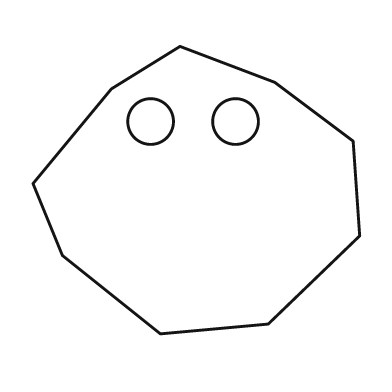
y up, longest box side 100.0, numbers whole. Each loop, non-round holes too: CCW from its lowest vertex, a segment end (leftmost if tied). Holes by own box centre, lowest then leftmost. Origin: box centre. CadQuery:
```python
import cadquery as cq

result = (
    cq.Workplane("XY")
    .moveTo(-11.0, -44.0)
    .lineTo(22.0, -41.0)
    .lineTo(50.0, -14.0)
    .lineTo(48.0, 15.0)
    .lineTo(24.0, 33.0)
    .lineTo(-5.0, 44.0)
    .lineTo(-26.0, 31.0)
    .lineTo(-50.0, 2.0)
    .lineTo(-41.0, -20.0)
    .close()
    .moveTo(-14.0, 21.0)
    .circle(7.0)
    .moveTo(12.0, 21.0)
    .circle(7.0)
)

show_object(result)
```